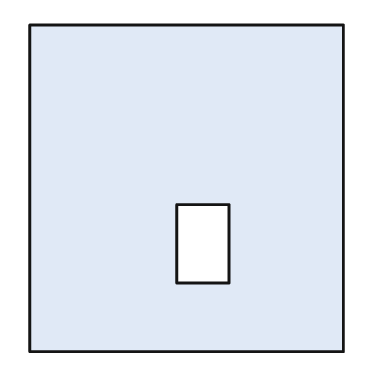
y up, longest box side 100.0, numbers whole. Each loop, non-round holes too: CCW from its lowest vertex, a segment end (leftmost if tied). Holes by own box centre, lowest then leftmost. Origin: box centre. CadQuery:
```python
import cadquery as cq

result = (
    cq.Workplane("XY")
    .moveTo(-48.0, -50.0)
    .lineTo(48.0, -50.0)
    .lineTo(48.0, 50.0)
    .lineTo(-48.0, 50.0)
    .close()
    .moveTo(-3.0, -29.0)
    .lineTo(13.0, -29.0)
    .lineTo(13.0, -5.0)
    .lineTo(-3.0, -5.0)
    .close()
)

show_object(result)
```